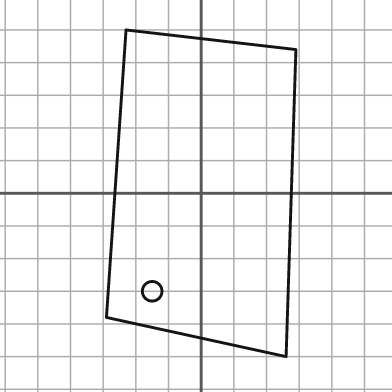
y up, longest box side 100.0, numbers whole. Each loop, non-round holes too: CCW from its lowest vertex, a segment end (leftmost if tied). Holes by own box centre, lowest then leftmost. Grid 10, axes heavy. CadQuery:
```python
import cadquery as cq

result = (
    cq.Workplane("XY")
    .moveTo(26.0, -50.0)
    .lineTo(29.0, 44.0)
    .lineTo(-23.0, 50.0)
    .lineTo(-29.0, -38.0)
    .close()
    .moveTo(-15.0, -30.0)
    .circle(3.0)
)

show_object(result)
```